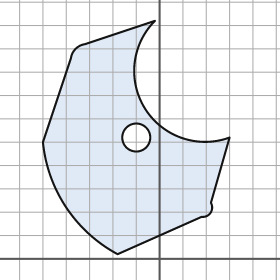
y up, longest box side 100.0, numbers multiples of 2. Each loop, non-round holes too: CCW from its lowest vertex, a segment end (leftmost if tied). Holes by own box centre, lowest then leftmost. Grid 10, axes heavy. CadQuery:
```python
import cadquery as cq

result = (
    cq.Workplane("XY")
    .moveTo(-18.0, 2.0)
    .lineTo(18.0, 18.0)
    .threePointArc((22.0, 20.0), (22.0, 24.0))
    .lineTo(30.0, 52.0)
    .threePointArc((-6.0, 64.0), (-2.0, 102.0))
    .lineTo(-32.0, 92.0)
    .threePointArc((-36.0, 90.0), (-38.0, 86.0))
    .lineTo(-50.0, 50.0)
    .threePointArc((-40.0, 22.0), (-18.0, 2.0))
    .close()
    .moveTo(-10.0, 52.0)
    .circle(6.0)
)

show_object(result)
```